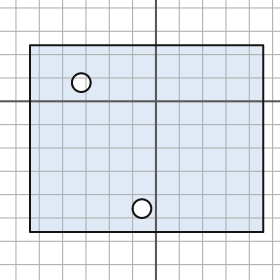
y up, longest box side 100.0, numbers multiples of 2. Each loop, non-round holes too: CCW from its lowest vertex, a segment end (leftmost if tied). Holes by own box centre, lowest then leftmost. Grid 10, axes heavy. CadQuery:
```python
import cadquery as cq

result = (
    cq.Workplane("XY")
    .moveTo(-54.0, -56.0)
    .lineTo(46.0, -56.0)
    .lineTo(46.0, 24.0)
    .lineTo(-54.0, 24.0)
    .close()
    .moveTo(-6.0, -46.0)
    .circle(4.0)
    .moveTo(-32.0, 8.0)
    .circle(4.0)
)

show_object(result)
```